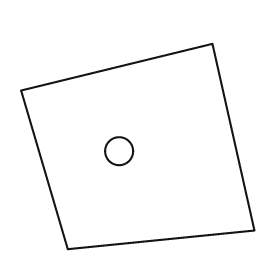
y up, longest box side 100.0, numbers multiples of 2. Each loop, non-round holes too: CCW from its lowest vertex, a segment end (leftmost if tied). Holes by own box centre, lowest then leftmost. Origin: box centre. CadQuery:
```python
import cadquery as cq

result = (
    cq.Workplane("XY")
    .moveTo(-30.0, -44.0)
    .lineTo(50.0, -36.0)
    .lineTo(32.0, 44.0)
    .lineTo(-50.0, 24.0)
    .close()
    .moveTo(-8.0, -2.0)
    .circle(6.0)
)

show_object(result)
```